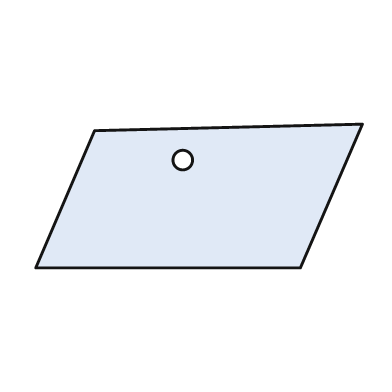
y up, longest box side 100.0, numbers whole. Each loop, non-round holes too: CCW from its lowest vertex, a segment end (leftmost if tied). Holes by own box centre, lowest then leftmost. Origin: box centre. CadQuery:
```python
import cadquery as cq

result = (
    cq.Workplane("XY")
    .moveTo(-50.0, -22.0)
    .lineTo(31.0, -22.0)
    .lineTo(50.0, 22.0)
    .lineTo(-32.0, 20.0)
    .close()
    .moveTo(-5.0, 11.0)
    .circle(3.0)
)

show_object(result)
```